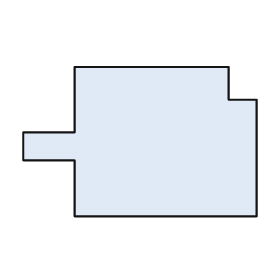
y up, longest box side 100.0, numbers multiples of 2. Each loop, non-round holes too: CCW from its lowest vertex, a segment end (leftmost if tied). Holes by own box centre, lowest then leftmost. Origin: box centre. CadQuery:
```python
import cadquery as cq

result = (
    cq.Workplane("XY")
    .moveTo(-28.0, -32.0)
    .lineTo(50.0, -32.0)
    .lineTo(50.0, 18.0)
    .lineTo(38.0, 18.0)
    .lineTo(38.0, 32.0)
    .lineTo(-28.0, 32.0)
    .lineTo(-28.0, 4.0)
    .lineTo(-50.0, 4.0)
    .lineTo(-50.0, -8.0)
    .lineTo(-28.0, -8.0)
    .close()
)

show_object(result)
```